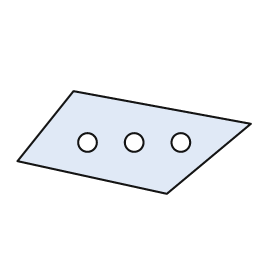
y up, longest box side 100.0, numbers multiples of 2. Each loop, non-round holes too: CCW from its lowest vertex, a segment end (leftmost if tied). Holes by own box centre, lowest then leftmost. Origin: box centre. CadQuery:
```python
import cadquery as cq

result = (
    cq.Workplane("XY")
    .moveTo(14.0, -22.0)
    .lineTo(50.0, 8.0)
    .lineTo(-26.0, 22.0)
    .lineTo(-50.0, -8.0)
    .close()
    .moveTo(-20.0, 0.0)
    .circle(4.0)
    .moveTo(0.0, 0.0)
    .circle(4.0)
    .moveTo(20.0, 0.0)
    .circle(4.0)
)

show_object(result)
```